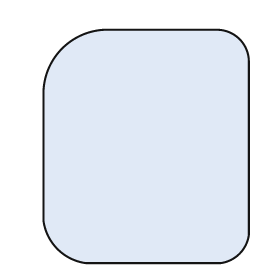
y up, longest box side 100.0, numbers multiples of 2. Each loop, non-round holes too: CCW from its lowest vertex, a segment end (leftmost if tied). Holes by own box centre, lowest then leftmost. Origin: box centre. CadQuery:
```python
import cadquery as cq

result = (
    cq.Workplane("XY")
    .moveTo(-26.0, -50.0)
    .lineTo(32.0, -50.0)
    .threePointArc((40.0, -46.0), (44.0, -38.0))
    .lineTo(44.0, 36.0)
    .threePointArc((40.0, 46.0), (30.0, 50.0))
    .lineTo(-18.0, 50.0)
    .threePointArc((-36.0, 42.0), (-44.0, 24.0))
    .lineTo(-44.0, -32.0)
    .threePointArc((-38.0, -44.0), (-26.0, -50.0))
    .close()
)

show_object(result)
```